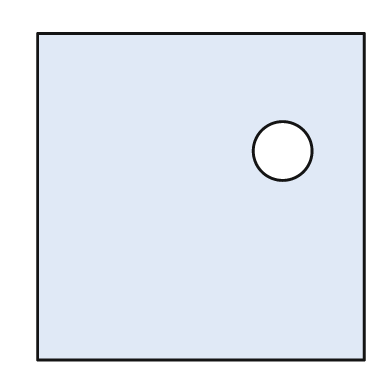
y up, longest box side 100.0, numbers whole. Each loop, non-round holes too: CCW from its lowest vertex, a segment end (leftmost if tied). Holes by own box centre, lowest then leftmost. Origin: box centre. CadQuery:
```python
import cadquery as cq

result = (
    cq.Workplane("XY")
    .moveTo(-50.0, -50.0)
    .lineTo(50.0, -50.0)
    .lineTo(50.0, 50.0)
    .lineTo(-50.0, 50.0)
    .close()
    .moveTo(25.0, 14.0)
    .circle(9.0)
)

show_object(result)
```